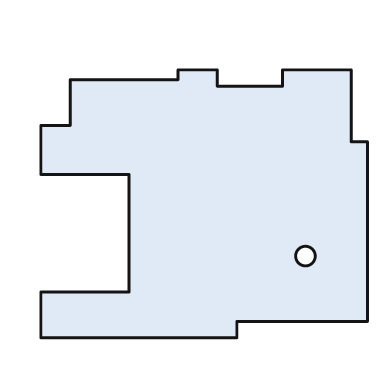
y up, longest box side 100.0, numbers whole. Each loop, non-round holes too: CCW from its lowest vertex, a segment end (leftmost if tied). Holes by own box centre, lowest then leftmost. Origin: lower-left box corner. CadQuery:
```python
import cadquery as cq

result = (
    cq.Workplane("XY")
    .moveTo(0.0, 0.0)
    .lineTo(60.0, 0.0)
    .lineTo(60.0, 5.0)
    .lineTo(100.0, 5.0)
    .lineTo(100.0, 60.0)
    .lineTo(95.0, 60.0)
    .lineTo(95.0, 82.0)
    .lineTo(74.0, 82.0)
    .lineTo(74.0, 77.0)
    .lineTo(54.0, 77.0)
    .lineTo(54.0, 82.0)
    .lineTo(42.0, 82.0)
    .lineTo(42.0, 79.0)
    .lineTo(9.0, 79.0)
    .lineTo(9.0, 65.0)
    .lineTo(0.0, 65.0)
    .lineTo(0.0, 50.0)
    .lineTo(27.0, 50.0)
    .lineTo(27.0, 14.0)
    .lineTo(0.0, 14.0)
    .close()
    .moveTo(81.0, 25.0)
    .circle(3.0)
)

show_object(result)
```